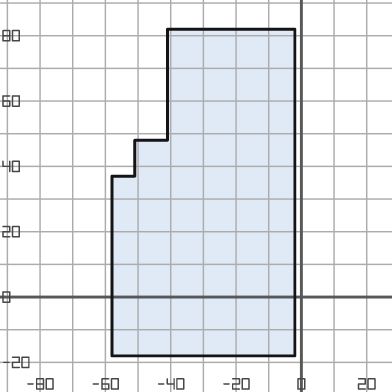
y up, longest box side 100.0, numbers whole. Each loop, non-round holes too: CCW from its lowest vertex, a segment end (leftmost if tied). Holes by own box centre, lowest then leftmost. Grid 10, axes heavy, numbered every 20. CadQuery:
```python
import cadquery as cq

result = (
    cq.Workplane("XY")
    .moveTo(-58.0, -18.0)
    .lineTo(-2.0, -18.0)
    .lineTo(-2.0, 82.0)
    .lineTo(-41.0, 82.0)
    .lineTo(-41.0, 48.0)
    .lineTo(-51.0, 48.0)
    .lineTo(-51.0, 37.0)
    .lineTo(-58.0, 37.0)
    .close()
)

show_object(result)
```